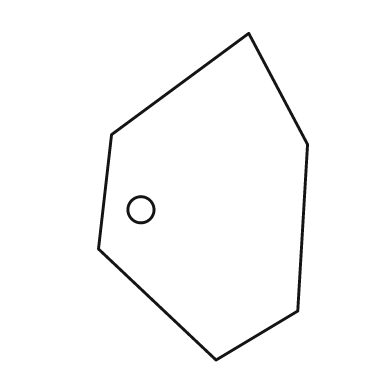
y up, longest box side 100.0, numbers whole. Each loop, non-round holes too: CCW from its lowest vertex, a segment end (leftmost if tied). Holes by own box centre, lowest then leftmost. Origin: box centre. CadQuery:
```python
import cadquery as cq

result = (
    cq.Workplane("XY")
    .moveTo(4.0, -50.0)
    .lineTo(29.0, -35.0)
    .lineTo(32.0, 16.0)
    .lineTo(14.0, 50.0)
    .lineTo(-28.0, 19.0)
    .lineTo(-32.0, -16.0)
    .close()
    .moveTo(-19.0, -4.0)
    .circle(4.0)
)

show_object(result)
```